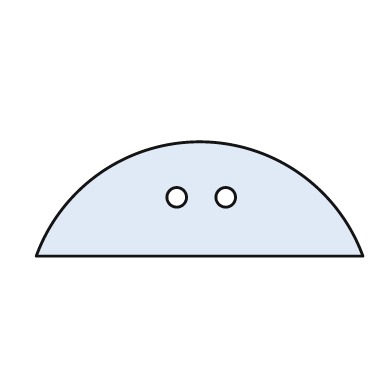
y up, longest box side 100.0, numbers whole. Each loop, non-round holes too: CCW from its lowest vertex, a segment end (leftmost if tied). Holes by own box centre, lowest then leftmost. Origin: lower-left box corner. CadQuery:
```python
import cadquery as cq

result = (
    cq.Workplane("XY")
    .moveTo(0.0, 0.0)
    .lineTo(100.0, 0.0)
    .threePointArc((50.0, 35.0), (0.0, 0.0))
    .close()
    .moveTo(43.0, 18.0)
    .circle(3.0)
    .moveTo(58.0, 18.0)
    .circle(3.0)
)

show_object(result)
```